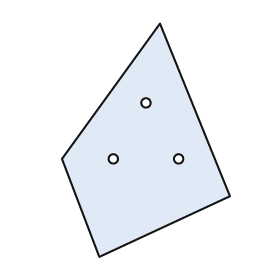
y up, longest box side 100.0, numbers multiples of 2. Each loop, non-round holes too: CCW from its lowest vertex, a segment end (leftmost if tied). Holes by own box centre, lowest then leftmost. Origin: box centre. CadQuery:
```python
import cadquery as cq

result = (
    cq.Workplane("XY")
    .moveTo(-20.0, -50.0)
    .lineTo(36.0, -24.0)
    .lineTo(6.0, 50.0)
    .lineTo(-36.0, -8.0)
    .close()
    .moveTo(-14.0, -8.0)
    .circle(2.0)
    .moveTo(14.0, -8.0)
    .circle(2.0)
    .moveTo(0.0, 16.0)
    .circle(2.0)
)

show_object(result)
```